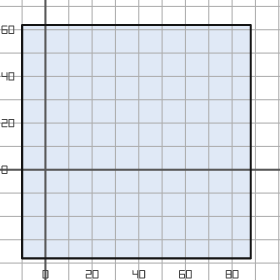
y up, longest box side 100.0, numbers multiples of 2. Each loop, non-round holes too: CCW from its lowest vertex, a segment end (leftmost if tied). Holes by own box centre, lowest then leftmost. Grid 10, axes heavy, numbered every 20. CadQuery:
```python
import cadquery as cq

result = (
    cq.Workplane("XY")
    .moveTo(-10.0, -38.0)
    .lineTo(88.0, -38.0)
    .lineTo(88.0, 62.0)
    .lineTo(-10.0, 62.0)
    .close()
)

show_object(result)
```